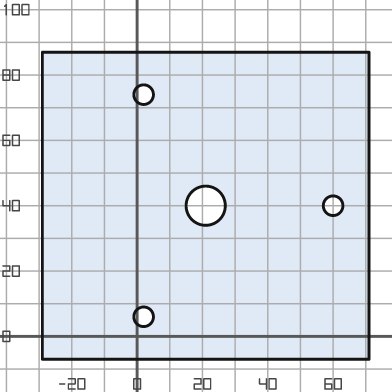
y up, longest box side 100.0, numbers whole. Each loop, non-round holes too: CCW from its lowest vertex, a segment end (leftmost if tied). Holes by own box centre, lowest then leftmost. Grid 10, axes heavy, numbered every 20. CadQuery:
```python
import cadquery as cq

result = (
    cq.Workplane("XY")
    .moveTo(-29.0, -7.0)
    .lineTo(71.0, -7.0)
    .lineTo(71.0, 87.0)
    .lineTo(-29.0, 87.0)
    .close()
    .moveTo(2.0, 6.0)
    .circle(3.0)
    .moveTo(21.0, 40.0)
    .circle(6.0)
    .moveTo(60.0, 40.0)
    .circle(3.0)
    .moveTo(2.0, 74.0)
    .circle(3.0)
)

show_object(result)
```